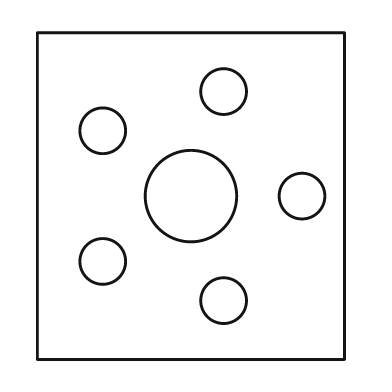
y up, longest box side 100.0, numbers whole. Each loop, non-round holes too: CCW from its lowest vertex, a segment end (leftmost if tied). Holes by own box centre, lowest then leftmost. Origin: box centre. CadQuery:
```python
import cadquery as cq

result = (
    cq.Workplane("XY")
    .moveTo(-47.0, -50.0)
    .lineTo(47.0, -50.0)
    .lineTo(47.0, 50.0)
    .lineTo(-47.0, 50.0)
    .close()
    .moveTo(10.0, -32.0)
    .circle(7.0)
    .moveTo(-27.0, -20.0)
    .circle(7.0)
    .moveTo(0.0, 0.0)
    .circle(14.0)
    .moveTo(34.0, 0.0)
    .circle(7.0)
    .moveTo(-27.0, 20.0)
    .circle(7.0)
    .moveTo(10.0, 32.0)
    .circle(7.0)
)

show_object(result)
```